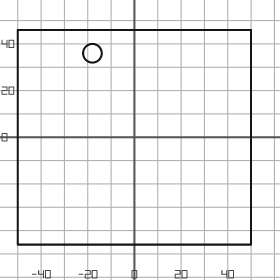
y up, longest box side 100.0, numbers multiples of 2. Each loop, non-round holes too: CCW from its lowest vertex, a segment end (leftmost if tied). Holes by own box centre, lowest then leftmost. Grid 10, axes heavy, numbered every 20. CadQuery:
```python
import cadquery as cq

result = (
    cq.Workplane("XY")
    .moveTo(-50.0, -46.0)
    .lineTo(50.0, -46.0)
    .lineTo(50.0, 46.0)
    .lineTo(-50.0, 46.0)
    .close()
    .moveTo(-18.0, 36.0)
    .circle(4.0)
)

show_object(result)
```